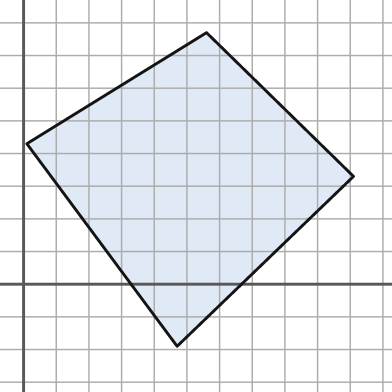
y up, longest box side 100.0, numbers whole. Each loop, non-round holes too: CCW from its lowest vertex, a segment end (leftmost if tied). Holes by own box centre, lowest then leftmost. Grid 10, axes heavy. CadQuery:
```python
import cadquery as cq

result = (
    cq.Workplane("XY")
    .moveTo(47.0, -19.0)
    .lineTo(101.0, 33.0)
    .lineTo(56.0, 77.0)
    .lineTo(1.0, 43.0)
    .close()
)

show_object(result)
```